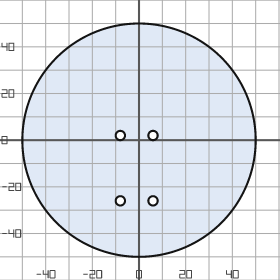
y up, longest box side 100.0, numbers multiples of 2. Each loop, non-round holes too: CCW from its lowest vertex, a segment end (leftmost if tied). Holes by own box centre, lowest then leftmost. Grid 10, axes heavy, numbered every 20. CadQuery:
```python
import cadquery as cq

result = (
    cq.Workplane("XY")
    .moveTo(0.0, 0.0)
    .circle(50.0)
    .moveTo(-8.0, -26.0)
    .circle(2.0)
    .moveTo(6.0, -26.0)
    .circle(2.0)
    .moveTo(-8.0, 2.0)
    .circle(2.0)
    .moveTo(6.0, 2.0)
    .circle(2.0)
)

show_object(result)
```